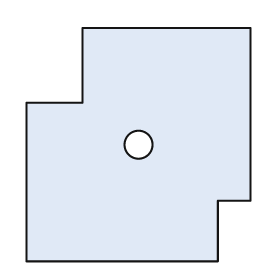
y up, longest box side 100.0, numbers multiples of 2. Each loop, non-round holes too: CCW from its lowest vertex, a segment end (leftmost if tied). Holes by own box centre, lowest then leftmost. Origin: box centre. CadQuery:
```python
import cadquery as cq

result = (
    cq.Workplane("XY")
    .moveTo(-48.0, -50.0)
    .lineTo(34.0, -50.0)
    .lineTo(34.0, -24.0)
    .lineTo(48.0, -24.0)
    .lineTo(48.0, 50.0)
    .lineTo(-24.0, 50.0)
    .lineTo(-24.0, 18.0)
    .lineTo(-48.0, 18.0)
    .close()
    .moveTo(0.0, 0.0)
    .circle(6.0)
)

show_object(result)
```